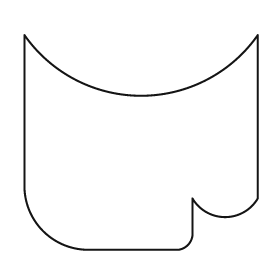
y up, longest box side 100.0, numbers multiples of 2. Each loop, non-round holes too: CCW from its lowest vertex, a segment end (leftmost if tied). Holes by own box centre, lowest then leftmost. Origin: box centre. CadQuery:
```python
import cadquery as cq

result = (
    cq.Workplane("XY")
    .moveTo(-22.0, -46.0)
    .lineTo(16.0, -46.0)
    .threePointArc((20.0, -44.0), (22.0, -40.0))
    .lineTo(22.0, -24.0)
    .threePointArc((36.0, -32.0), (50.0, -24.0))
    .lineTo(50.0, 46.0)
    .threePointArc((0.0, 20.0), (-50.0, 46.0))
    .lineTo(-50.0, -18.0)
    .threePointArc((-42.0, -38.0), (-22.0, -46.0))
    .close()
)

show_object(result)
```